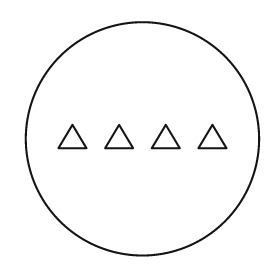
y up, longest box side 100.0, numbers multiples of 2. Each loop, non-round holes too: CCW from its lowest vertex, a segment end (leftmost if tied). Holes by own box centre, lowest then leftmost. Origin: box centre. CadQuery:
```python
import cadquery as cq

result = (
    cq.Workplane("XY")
    .moveTo(0.0, 0.0)
    .circle(50.0)
    .moveTo(-36.0, -4.0)
    .lineTo(-24.0, -4.0)
    .lineTo(-30.0, 6.0)
    .close()
    .moveTo(-16.0, -4.0)
    .lineTo(-4.0, -4.0)
    .lineTo(-10.0, 6.0)
    .close()
    .moveTo(4.0, -4.0)
    .lineTo(16.0, -4.0)
    .lineTo(10.0, 6.0)
    .close()
    .moveTo(24.0, -4.0)
    .lineTo(36.0, -4.0)
    .lineTo(30.0, 6.0)
    .close()
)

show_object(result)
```